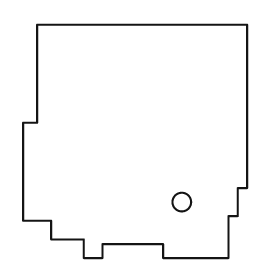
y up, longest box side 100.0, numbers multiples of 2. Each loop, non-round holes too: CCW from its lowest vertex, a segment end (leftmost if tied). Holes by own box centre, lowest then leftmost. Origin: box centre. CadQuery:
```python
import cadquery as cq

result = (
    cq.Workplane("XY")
    .moveTo(-22.0, -50.0)
    .lineTo(-14.0, -50.0)
    .lineTo(-14.0, -44.0)
    .lineTo(12.0, -44.0)
    .lineTo(12.0, -50.0)
    .lineTo(40.0, -50.0)
    .lineTo(40.0, -32.0)
    .lineTo(44.0, -32.0)
    .lineTo(44.0, -20.0)
    .lineTo(48.0, -20.0)
    .lineTo(48.0, 50.0)
    .lineTo(-42.0, 50.0)
    .lineTo(-42.0, 8.0)
    .lineTo(-48.0, 8.0)
    .lineTo(-48.0, -34.0)
    .lineTo(-36.0, -34.0)
    .lineTo(-36.0, -42.0)
    .lineTo(-22.0, -42.0)
    .close()
    .moveTo(20.0, -26.0)
    .circle(4.0)
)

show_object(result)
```